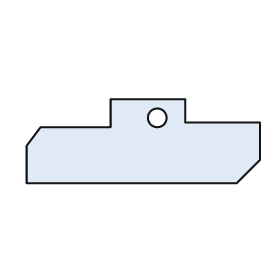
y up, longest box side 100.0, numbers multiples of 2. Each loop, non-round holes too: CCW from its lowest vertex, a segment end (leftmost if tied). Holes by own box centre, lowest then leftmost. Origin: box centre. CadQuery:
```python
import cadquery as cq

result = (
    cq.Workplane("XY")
    .moveTo(-50.0, -18.0)
    .lineTo(40.0, -18.0)
    .lineTo(50.0, -8.0)
    .lineTo(50.0, 8.0)
    .lineTo(18.0, 8.0)
    .lineTo(18.0, 18.0)
    .lineTo(-14.0, 18.0)
    .lineTo(-14.0, 6.0)
    .lineTo(-44.0, 6.0)
    .lineTo(-50.0, -2.0)
    .close()
    .moveTo(6.0, 10.0)
    .circle(4.0)
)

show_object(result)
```